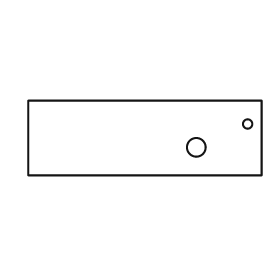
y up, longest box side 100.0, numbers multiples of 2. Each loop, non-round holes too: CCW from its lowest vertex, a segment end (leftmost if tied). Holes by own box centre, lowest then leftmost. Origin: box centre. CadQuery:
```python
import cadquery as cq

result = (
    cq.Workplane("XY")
    .moveTo(-50.0, -16.0)
    .lineTo(50.0, -16.0)
    .lineTo(50.0, 16.0)
    .lineTo(-50.0, 16.0)
    .close()
    .moveTo(22.0, -4.0)
    .circle(4.0)
    .moveTo(44.0, 6.0)
    .circle(2.0)
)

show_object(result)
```